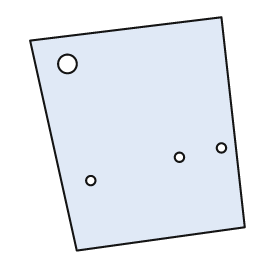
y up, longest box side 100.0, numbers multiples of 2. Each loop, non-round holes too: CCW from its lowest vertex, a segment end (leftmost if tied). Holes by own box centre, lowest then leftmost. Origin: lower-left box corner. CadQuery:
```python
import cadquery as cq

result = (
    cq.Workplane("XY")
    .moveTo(20.0, 0.0)
    .lineTo(92.0, 10.0)
    .lineTo(82.0, 100.0)
    .lineTo(0.0, 90.0)
    .close()
    .moveTo(26.0, 30.0)
    .circle(2.0)
    .moveTo(64.0, 40.0)
    .circle(2.0)
    .moveTo(82.0, 44.0)
    .circle(2.0)
    .moveTo(16.0, 80.0)
    .circle(4.0)
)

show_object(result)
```